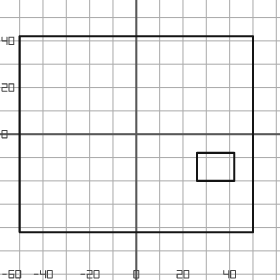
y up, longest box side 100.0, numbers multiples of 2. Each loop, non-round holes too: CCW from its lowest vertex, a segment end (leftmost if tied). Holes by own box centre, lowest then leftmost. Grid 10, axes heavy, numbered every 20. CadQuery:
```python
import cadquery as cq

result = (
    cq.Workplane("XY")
    .moveTo(-50.0, -42.0)
    .lineTo(50.0, -42.0)
    .lineTo(50.0, 42.0)
    .lineTo(-50.0, 42.0)
    .close()
    .moveTo(26.0, -20.0)
    .lineTo(42.0, -20.0)
    .lineTo(42.0, -8.0)
    .lineTo(26.0, -8.0)
    .close()
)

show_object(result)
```